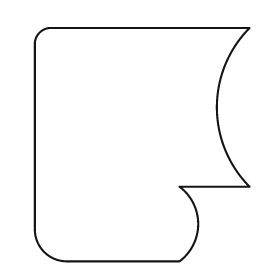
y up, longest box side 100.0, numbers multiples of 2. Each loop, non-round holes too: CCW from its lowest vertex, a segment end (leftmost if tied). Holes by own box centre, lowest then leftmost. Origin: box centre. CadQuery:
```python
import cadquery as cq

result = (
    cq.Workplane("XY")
    .moveTo(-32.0, -50.0)
    .lineTo(16.0, -50.0)
    .threePointArc((24.0, -34.0), (16.0, -18.0))
    .lineTo(46.0, -18.0)
    .threePointArc((32.0, 16.0), (46.0, 50.0))
    .lineTo(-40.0, 50.0)
    .threePointArc((-44.0, 48.0), (-46.0, 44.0))
    .lineTo(-46.0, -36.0)
    .threePointArc((-42.0, -46.0), (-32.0, -50.0))
    .close()
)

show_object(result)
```